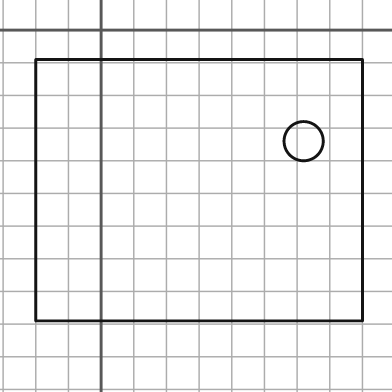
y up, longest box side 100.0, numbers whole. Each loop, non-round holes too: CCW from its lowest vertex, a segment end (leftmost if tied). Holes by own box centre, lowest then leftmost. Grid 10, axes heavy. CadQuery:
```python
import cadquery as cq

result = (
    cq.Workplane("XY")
    .moveTo(-20.0, -89.0)
    .lineTo(80.0, -89.0)
    .lineTo(80.0, -9.0)
    .lineTo(-20.0, -9.0)
    .close()
    .moveTo(62.0, -34.0)
    .circle(6.0)
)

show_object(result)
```